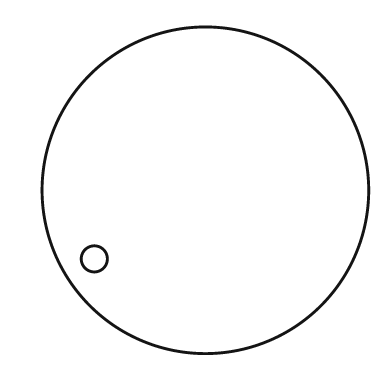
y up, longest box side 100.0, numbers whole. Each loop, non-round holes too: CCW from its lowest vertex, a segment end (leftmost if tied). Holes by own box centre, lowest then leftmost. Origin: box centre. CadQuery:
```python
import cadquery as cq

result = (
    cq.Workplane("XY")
    .moveTo(0.0, 0.0)
    .circle(50.0)
    .moveTo(-34.0, -21.0)
    .circle(4.0)
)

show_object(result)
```